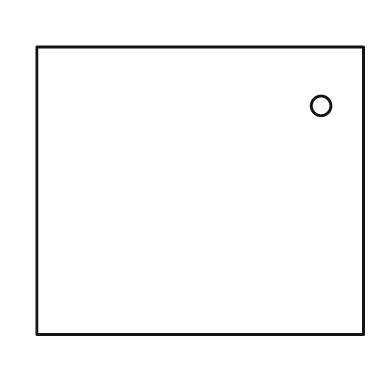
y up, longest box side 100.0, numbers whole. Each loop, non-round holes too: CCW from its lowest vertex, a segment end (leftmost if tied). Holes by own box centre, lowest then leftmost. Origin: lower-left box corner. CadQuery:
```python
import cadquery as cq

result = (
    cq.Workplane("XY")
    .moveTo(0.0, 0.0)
    .lineTo(100.0, 0.0)
    .lineTo(100.0, 88.0)
    .lineTo(0.0, 88.0)
    .close()
    .moveTo(87.0, 70.0)
    .circle(3.0)
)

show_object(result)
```